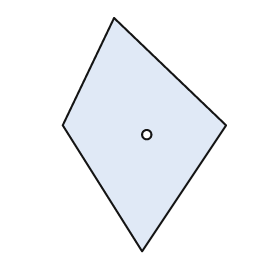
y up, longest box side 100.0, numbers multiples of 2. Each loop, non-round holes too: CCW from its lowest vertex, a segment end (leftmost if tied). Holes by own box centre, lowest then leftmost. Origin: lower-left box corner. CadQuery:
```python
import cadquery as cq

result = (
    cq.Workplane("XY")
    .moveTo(34.0, 0.0)
    .lineTo(70.0, 54.0)
    .lineTo(22.0, 100.0)
    .lineTo(0.0, 54.0)
    .close()
    .moveTo(36.0, 50.0)
    .circle(2.0)
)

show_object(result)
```